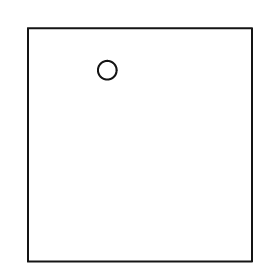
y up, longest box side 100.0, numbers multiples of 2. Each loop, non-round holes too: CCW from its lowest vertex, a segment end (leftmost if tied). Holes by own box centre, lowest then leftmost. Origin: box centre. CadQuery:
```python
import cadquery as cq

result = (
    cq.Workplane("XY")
    .moveTo(-48.0, -50.0)
    .lineTo(48.0, -50.0)
    .lineTo(48.0, 50.0)
    .lineTo(-48.0, 50.0)
    .close()
    .moveTo(-14.0, 32.0)
    .circle(4.0)
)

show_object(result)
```